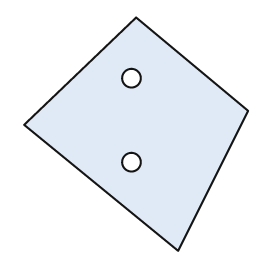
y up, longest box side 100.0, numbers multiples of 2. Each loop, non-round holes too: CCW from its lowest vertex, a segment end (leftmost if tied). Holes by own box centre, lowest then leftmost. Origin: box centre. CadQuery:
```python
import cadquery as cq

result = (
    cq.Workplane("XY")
    .moveTo(18.0, -50.0)
    .lineTo(48.0, 10.0)
    .lineTo(0.0, 50.0)
    .lineTo(-48.0, 4.0)
    .close()
    .moveTo(-2.0, -12.0)
    .circle(4.0)
    .moveTo(-2.0, 24.0)
    .circle(4.0)
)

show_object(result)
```